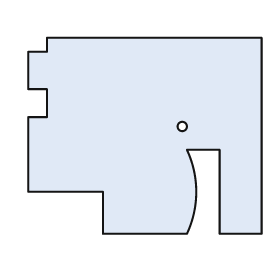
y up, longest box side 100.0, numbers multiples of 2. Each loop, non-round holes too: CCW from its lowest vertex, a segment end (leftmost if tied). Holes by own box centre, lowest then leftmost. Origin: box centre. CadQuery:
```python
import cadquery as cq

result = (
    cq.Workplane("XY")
    .moveTo(-18.0, -42.0)
    .lineTo(18.0, -42.0)
    .threePointArc((22.0, -24.0), (18.0, -6.0))
    .lineTo(32.0, -6.0)
    .lineTo(32.0, -42.0)
    .lineTo(50.0, -42.0)
    .lineTo(50.0, 42.0)
    .lineTo(-42.0, 42.0)
    .lineTo(-42.0, 36.0)
    .lineTo(-50.0, 36.0)
    .lineTo(-50.0, 20.0)
    .lineTo(-42.0, 20.0)
    .lineTo(-42.0, 8.0)
    .lineTo(-50.0, 8.0)
    .lineTo(-50.0, -24.0)
    .lineTo(-18.0, -24.0)
    .close()
    .moveTo(16.0, 4.0)
    .circle(2.0)
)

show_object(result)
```